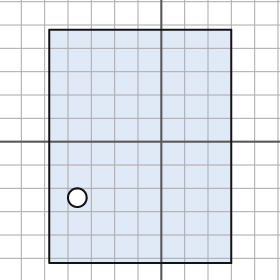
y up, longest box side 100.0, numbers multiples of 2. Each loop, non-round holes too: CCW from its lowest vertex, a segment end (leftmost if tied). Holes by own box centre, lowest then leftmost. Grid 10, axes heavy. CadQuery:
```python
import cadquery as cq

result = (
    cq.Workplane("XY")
    .moveTo(-48.0, -52.0)
    .lineTo(30.0, -52.0)
    .lineTo(30.0, 48.0)
    .lineTo(-48.0, 48.0)
    .close()
    .moveTo(-36.0, -24.0)
    .circle(4.0)
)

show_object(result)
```